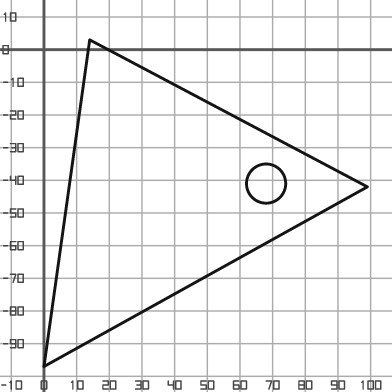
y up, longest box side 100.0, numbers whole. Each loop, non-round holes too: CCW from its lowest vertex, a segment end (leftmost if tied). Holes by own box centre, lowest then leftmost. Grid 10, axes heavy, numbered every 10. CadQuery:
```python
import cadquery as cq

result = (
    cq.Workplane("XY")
    .moveTo(0.0, -97.0)
    .lineTo(99.0, -42.0)
    .lineTo(14.0, 3.0)
    .close()
    .moveTo(68.0, -41.0)
    .circle(6.0)
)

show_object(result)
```